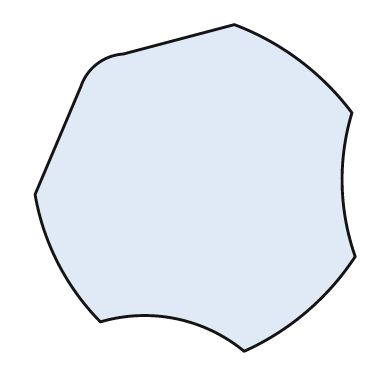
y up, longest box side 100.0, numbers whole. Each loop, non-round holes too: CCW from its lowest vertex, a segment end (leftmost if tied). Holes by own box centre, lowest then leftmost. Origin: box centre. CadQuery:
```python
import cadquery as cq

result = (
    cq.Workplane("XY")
    .moveTo(15.0, -50.0)
    .threePointArc((34.0, -38.0), (49.0, -21.0))
    .threePointArc((45.0, 1.0), (48.0, 23.0))
    .threePointArc((32.0, 39.0), (12.0, 50.0))
    .lineTo(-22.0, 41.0)
    .threePointArc((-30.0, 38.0), (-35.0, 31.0))
    .lineTo(-49.0, -2.0)
    .threePointArc((-42.0, -23.0), (-29.0, -41.0))
    .threePointArc((-6.0, -40.0), (15.0, -50.0))
    .close()
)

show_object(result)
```